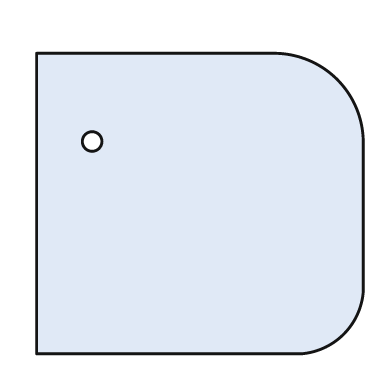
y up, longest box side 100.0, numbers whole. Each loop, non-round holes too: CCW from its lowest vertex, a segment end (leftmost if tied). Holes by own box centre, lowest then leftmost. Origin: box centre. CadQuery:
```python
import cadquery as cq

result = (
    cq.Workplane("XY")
    .moveTo(-50.0, -46.0)
    .lineTo(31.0, -46.0)
    .threePointArc((44.0, -40.0), (50.0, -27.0))
    .lineTo(50.0, 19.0)
    .threePointArc((42.0, 38.0), (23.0, 46.0))
    .lineTo(-50.0, 46.0)
    .close()
    .moveTo(-33.0, 19.0)
    .circle(3.0)
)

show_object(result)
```